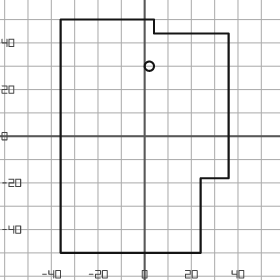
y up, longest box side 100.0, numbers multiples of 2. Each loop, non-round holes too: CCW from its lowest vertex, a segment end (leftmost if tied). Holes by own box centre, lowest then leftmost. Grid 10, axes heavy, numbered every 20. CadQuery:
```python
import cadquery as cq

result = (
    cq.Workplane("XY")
    .moveTo(-36.0, -50.0)
    .lineTo(24.0, -50.0)
    .lineTo(24.0, -18.0)
    .lineTo(36.0, -18.0)
    .lineTo(36.0, 44.0)
    .lineTo(4.0, 44.0)
    .lineTo(4.0, 50.0)
    .lineTo(-36.0, 50.0)
    .close()
    .moveTo(2.0, 30.0)
    .circle(2.0)
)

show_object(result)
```